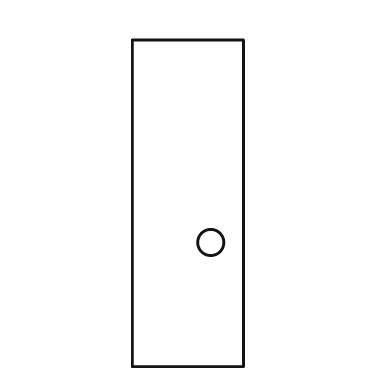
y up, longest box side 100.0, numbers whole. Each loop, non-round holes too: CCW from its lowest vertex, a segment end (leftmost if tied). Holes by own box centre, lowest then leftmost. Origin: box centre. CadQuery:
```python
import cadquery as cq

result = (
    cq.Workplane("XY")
    .moveTo(-17.0, -50.0)
    .lineTo(17.0, -50.0)
    .lineTo(17.0, 50.0)
    .lineTo(-17.0, 50.0)
    .close()
    .moveTo(7.0, -12.0)
    .circle(4.0)
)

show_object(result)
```